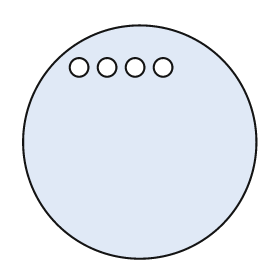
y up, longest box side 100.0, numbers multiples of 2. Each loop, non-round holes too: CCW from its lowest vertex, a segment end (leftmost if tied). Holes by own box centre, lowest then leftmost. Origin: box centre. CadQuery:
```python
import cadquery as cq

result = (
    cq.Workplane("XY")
    .moveTo(0.0, 0.0)
    .circle(50.0)
    .moveTo(-26.0, 32.0)
    .circle(4.0)
    .moveTo(-14.0, 32.0)
    .circle(4.0)
    .moveTo(-2.0, 32.0)
    .circle(4.0)
    .moveTo(10.0, 32.0)
    .circle(4.0)
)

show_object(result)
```